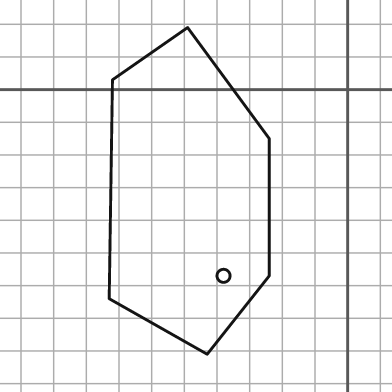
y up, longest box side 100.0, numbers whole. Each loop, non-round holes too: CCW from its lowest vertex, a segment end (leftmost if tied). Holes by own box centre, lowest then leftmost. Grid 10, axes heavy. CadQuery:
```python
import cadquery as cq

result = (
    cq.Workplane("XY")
    .moveTo(-43.0, -81.0)
    .lineTo(-24.0, -57.0)
    .lineTo(-24.0, -15.0)
    .lineTo(-49.0, 19.0)
    .lineTo(-72.0, 3.0)
    .lineTo(-73.0, -64.0)
    .close()
    .moveTo(-38.0, -57.0)
    .circle(2.0)
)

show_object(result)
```